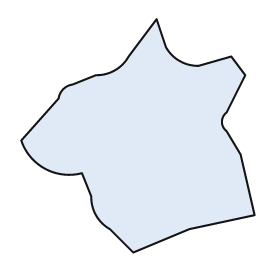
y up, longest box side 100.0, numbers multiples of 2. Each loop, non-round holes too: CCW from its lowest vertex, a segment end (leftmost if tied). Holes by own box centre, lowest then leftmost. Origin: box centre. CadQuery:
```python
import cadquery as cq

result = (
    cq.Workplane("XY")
    .moveTo(-2.0, -50.0)
    .lineTo(22.0, -40.0)
    .lineTo(50.0, -34.0)
    .lineTo(44.0, -8.0)
    .lineTo(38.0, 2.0)
    .threePointArc((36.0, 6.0), (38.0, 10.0))
    .lineTo(46.0, 26.0)
    .lineTo(40.0, 34.0)
    .lineTo(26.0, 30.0)
    .threePointArc((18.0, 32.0), (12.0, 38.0))
    .lineTo(8.0, 50.0)
    .lineTo(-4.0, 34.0)
    .threePointArc((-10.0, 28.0), (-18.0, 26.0))
    .lineTo(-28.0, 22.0)
    .threePointArc((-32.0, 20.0), (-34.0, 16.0))
    .lineTo(-50.0, -2.0)
    .threePointArc((-40.0, -14.0), (-24.0, -16.0))
    .lineTo(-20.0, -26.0)
    .threePointArc((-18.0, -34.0), (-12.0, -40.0))
    .close()
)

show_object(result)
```